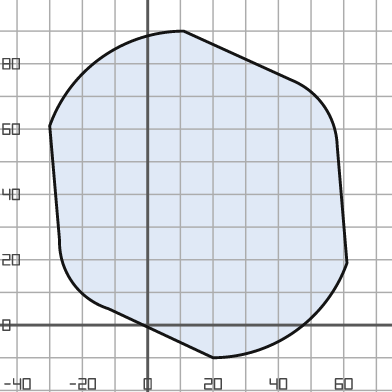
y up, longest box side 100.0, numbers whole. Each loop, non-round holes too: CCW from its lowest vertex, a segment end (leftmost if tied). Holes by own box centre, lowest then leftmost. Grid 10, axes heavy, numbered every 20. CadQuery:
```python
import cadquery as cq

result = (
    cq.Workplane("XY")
    .moveTo(20.0, -10.0)
    .threePointArc((45.0, -2.0), (61.0, 19.0))
    .lineTo(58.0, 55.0)
    .threePointArc((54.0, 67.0), (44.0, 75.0))
    .lineTo(11.0, 90.0)
    .threePointArc((-14.0, 82.0), (-30.0, 61.0))
    .lineTo(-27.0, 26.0)
    .threePointArc((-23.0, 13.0), (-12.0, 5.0))
    .close()
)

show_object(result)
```